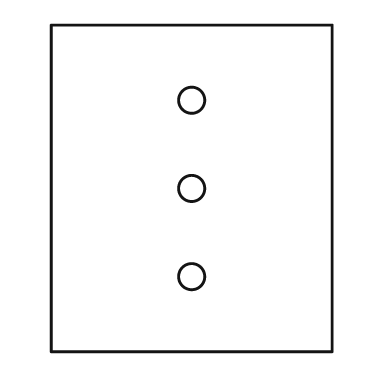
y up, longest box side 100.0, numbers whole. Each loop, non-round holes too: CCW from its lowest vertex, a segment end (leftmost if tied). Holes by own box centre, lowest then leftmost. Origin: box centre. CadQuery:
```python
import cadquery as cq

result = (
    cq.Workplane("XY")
    .moveTo(-43.0, -50.0)
    .lineTo(43.0, -50.0)
    .lineTo(43.0, 50.0)
    .lineTo(-43.0, 50.0)
    .close()
    .moveTo(0.0, -27.0)
    .circle(4.0)
    .moveTo(0.0, 0.0)
    .circle(4.0)
    .moveTo(0.0, 27.0)
    .circle(4.0)
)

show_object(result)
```